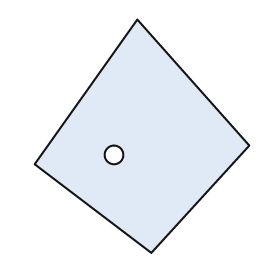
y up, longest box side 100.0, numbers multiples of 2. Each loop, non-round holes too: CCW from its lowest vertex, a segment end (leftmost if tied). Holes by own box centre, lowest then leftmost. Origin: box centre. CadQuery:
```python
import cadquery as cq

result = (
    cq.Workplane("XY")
    .moveTo(4.0, -50.0)
    .lineTo(46.0, -4.0)
    .lineTo(-2.0, 50.0)
    .lineTo(-46.0, -12.0)
    .close()
    .moveTo(-12.0, -8.0)
    .circle(4.0)
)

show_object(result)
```